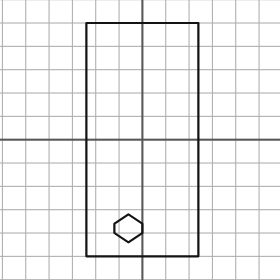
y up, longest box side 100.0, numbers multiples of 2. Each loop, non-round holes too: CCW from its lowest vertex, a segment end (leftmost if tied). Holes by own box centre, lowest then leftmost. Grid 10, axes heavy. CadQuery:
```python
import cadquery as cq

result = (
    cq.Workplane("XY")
    .moveTo(-24.0, -50.0)
    .lineTo(24.0, -50.0)
    .lineTo(24.0, 50.0)
    .lineTo(-24.0, 50.0)
    .close()
    .moveTo(-6.0, -44.0)
    .lineTo(0.0, -40.0)
    .lineTo(0.0, -36.0)
    .lineTo(-6.0, -32.0)
    .lineTo(-12.0, -36.0)
    .lineTo(-12.0, -40.0)
    .close()
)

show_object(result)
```